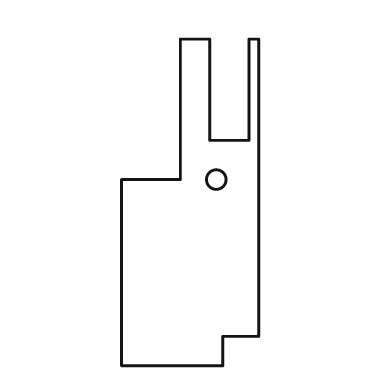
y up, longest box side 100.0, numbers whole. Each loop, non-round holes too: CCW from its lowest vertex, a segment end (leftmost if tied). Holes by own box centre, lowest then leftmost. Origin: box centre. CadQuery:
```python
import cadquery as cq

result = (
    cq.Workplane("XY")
    .moveTo(-21.0, -50.0)
    .lineTo(10.0, -50.0)
    .lineTo(10.0, -41.0)
    .lineTo(21.0, -41.0)
    .lineTo(21.0, 50.0)
    .lineTo(18.0, 50.0)
    .lineTo(18.0, 19.0)
    .lineTo(6.0, 19.0)
    .lineTo(6.0, 50.0)
    .lineTo(-3.0, 50.0)
    .lineTo(-3.0, 7.0)
    .lineTo(-21.0, 7.0)
    .close()
    .moveTo(8.0, 7.0)
    .circle(3.0)
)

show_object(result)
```